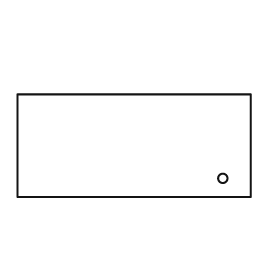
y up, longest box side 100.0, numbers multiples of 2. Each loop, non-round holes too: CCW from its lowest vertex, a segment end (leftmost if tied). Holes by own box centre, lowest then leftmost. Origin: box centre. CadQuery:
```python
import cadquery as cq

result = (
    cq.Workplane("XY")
    .moveTo(-50.0, -22.0)
    .lineTo(50.0, -22.0)
    .lineTo(50.0, 22.0)
    .lineTo(-50.0, 22.0)
    .close()
    .moveTo(38.0, -14.0)
    .circle(2.0)
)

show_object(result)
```